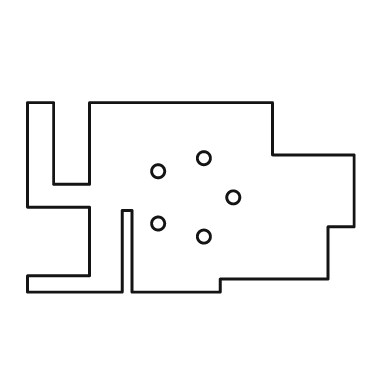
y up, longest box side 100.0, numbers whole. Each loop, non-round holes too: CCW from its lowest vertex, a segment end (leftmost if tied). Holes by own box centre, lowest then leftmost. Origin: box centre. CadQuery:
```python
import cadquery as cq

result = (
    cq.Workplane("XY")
    .moveTo(-50.0, -29.0)
    .lineTo(-21.0, -29.0)
    .lineTo(-21.0, -4.0)
    .lineTo(-18.0, -4.0)
    .lineTo(-18.0, -29.0)
    .lineTo(9.0, -29.0)
    .lineTo(9.0, -25.0)
    .lineTo(42.0, -25.0)
    .lineTo(42.0, -9.0)
    .lineTo(50.0, -9.0)
    .lineTo(50.0, 13.0)
    .lineTo(25.0, 13.0)
    .lineTo(25.0, 29.0)
    .lineTo(-31.0, 29.0)
    .lineTo(-31.0, 4.0)
    .lineTo(-42.0, 4.0)
    .lineTo(-42.0, 29.0)
    .lineTo(-50.0, 29.0)
    .lineTo(-50.0, -3.0)
    .lineTo(-31.0, -3.0)
    .lineTo(-31.0, -24.0)
    .lineTo(-50.0, -24.0)
    .close()
    .moveTo(4.0, -12.0)
    .circle(2.0)
    .moveTo(-10.0, -8.0)
    .circle(2.0)
    .moveTo(13.0, 0.0)
    .circle(2.0)
    .moveTo(-10.0, 8.0)
    .circle(2.0)
    .moveTo(4.0, 12.0)
    .circle(2.0)
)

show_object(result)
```